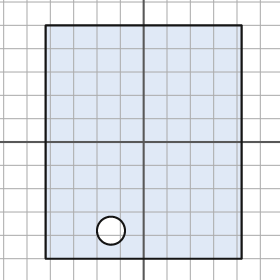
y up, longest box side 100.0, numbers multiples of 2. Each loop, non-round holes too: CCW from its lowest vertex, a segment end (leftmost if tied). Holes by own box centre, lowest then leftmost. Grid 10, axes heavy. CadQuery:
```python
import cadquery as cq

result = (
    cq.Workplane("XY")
    .moveTo(-42.0, -50.0)
    .lineTo(42.0, -50.0)
    .lineTo(42.0, 50.0)
    .lineTo(-42.0, 50.0)
    .close()
    .moveTo(-14.0, -38.0)
    .circle(6.0)
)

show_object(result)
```